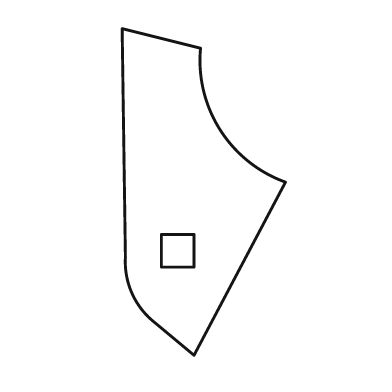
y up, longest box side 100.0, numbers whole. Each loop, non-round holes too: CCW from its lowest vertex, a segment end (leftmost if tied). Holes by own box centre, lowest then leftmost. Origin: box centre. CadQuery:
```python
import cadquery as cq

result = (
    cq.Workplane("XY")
    .moveTo(-3.0, -50.0)
    .lineTo(25.0, 3.0)
    .threePointArc((5.0, 19.0), (-1.0, 44.0))
    .lineTo(-25.0, 50.0)
    .lineTo(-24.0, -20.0)
    .threePointArc((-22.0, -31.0), (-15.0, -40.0))
    .close()
    .moveTo(-13.0, -23.0)
    .lineTo(-3.0, -23.0)
    .lineTo(-3.0, -13.0)
    .lineTo(-13.0, -13.0)
    .close()
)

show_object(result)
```